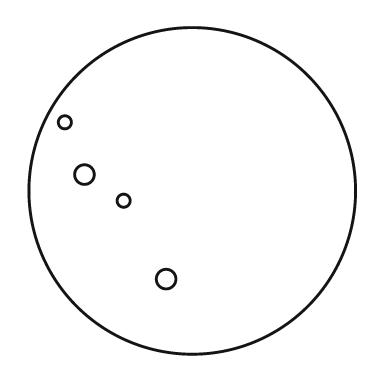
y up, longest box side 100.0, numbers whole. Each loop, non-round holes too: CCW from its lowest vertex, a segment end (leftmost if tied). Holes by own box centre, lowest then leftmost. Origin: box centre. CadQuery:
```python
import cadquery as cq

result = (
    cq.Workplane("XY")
    .moveTo(0.0, 0.0)
    .circle(50.0)
    .moveTo(-8.0, -27.0)
    .circle(3.0)
    .moveTo(-21.0, -3.0)
    .circle(2.0)
    .moveTo(-33.0, 5.0)
    .circle(3.0)
    .moveTo(-39.0, 21.0)
    .circle(2.0)
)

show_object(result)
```